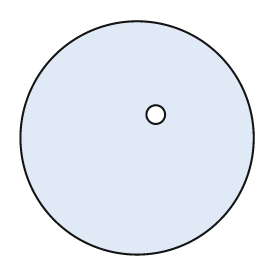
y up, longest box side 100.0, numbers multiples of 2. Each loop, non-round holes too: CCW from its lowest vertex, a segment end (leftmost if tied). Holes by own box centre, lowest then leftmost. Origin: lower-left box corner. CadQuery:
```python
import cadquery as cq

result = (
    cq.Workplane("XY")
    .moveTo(50.0, 50.0)
    .circle(50.0)
    .moveTo(58.0, 60.0)
    .circle(4.0)
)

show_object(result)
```